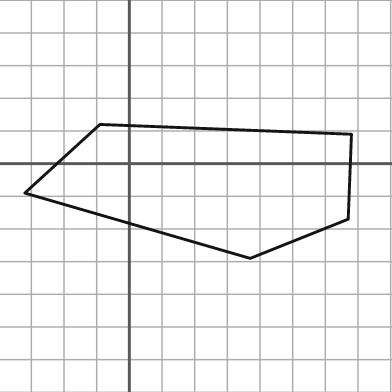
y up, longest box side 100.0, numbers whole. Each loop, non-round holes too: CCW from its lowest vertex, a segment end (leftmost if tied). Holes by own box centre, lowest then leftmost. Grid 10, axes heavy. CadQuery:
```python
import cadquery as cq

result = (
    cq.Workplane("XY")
    .moveTo(37.0, -29.0)
    .lineTo(67.0, -17.0)
    .lineTo(68.0, 9.0)
    .lineTo(-9.0, 12.0)
    .lineTo(-32.0, -9.0)
    .close()
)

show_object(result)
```